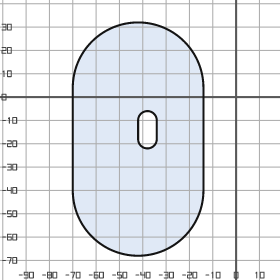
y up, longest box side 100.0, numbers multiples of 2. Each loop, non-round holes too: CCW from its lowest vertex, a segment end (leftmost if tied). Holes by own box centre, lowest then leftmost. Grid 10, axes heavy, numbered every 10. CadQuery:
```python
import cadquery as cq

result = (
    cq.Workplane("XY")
    .moveTo(-70.0, -40.0)
    .threePointArc((-42.0, -68.0), (-14.0, -40.0))
    .lineTo(-14.0, 4.0)
    .threePointArc((-42.0, 32.0), (-70.0, 4.0))
    .close()
    .moveTo(-42.0, -18.0)
    .threePointArc((-38.0, -22.0), (-34.0, -18.0))
    .lineTo(-34.0, -10.0)
    .threePointArc((-38.0, -6.0), (-42.0, -10.0))
    .close()
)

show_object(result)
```